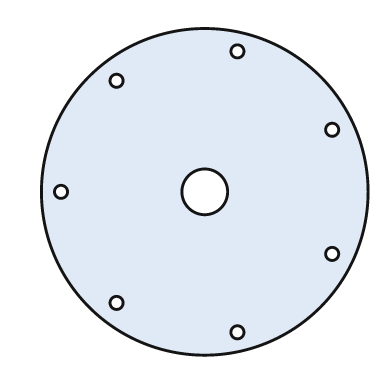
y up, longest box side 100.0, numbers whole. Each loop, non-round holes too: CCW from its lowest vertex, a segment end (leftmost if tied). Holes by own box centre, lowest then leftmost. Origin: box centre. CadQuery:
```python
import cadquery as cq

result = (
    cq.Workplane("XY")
    .moveTo(0.0, 0.0)
    .circle(50.0)
    .moveTo(10.0, -43.0)
    .circle(2.0)
    .moveTo(-27.0, -34.0)
    .circle(2.0)
    .moveTo(39.0, -19.0)
    .circle(2.0)
    .moveTo(-44.0, 0.0)
    .circle(2.0)
    .moveTo(0.0, 0.0)
    .circle(7.0)
    .moveTo(39.0, 19.0)
    .circle(2.0)
    .moveTo(-27.0, 34.0)
    .circle(2.0)
    .moveTo(10.0, 43.0)
    .circle(2.0)
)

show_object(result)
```